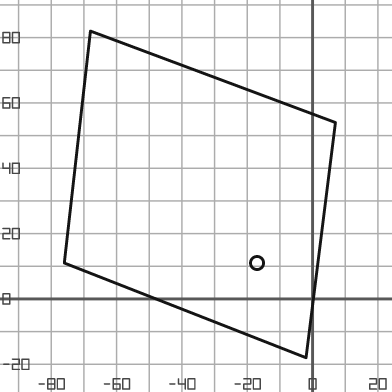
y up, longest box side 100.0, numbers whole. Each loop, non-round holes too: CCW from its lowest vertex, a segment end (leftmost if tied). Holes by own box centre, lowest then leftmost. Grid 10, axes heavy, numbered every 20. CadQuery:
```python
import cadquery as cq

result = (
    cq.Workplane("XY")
    .moveTo(-2.0, -18.0)
    .lineTo(7.0, 54.0)
    .lineTo(-68.0, 82.0)
    .lineTo(-76.0, 11.0)
    .close()
    .moveTo(-17.0, 11.0)
    .circle(2.0)
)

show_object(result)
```